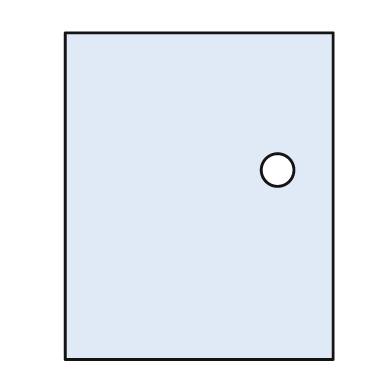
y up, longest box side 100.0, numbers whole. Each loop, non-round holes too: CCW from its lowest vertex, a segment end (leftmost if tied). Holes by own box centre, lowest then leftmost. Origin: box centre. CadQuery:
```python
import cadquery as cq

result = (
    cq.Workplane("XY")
    .moveTo(-41.0, -50.0)
    .lineTo(41.0, -50.0)
    .lineTo(41.0, 50.0)
    .lineTo(-41.0, 50.0)
    .close()
    .moveTo(24.0, 8.0)
    .circle(5.0)
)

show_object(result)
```